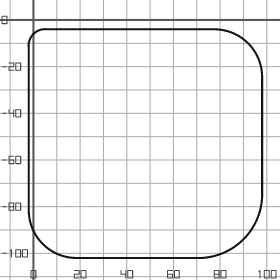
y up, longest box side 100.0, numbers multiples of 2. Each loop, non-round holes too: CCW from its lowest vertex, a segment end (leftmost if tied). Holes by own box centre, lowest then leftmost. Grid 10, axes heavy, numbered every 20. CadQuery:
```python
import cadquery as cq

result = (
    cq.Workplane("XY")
    .moveTo(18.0, -102.0)
    .lineTo(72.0, -102.0)
    .threePointArc((90.0, -94.0), (98.0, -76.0))
    .lineTo(98.0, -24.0)
    .threePointArc((92.0, -10.0), (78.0, -4.0))
    .lineTo(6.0, -4.0)
    .threePointArc((0.0, -6.0), (-2.0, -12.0))
    .lineTo(-2.0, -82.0)
    .threePointArc((4.0, -96.0), (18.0, -102.0))
    .close()
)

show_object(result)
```